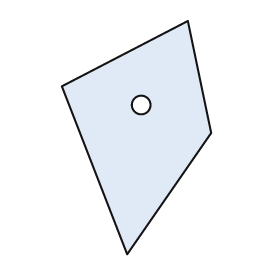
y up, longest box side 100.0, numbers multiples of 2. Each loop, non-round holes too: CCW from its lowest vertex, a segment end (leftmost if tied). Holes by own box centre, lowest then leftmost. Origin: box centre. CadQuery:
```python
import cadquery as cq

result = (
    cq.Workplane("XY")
    .moveTo(-4.0, -50.0)
    .lineTo(32.0, 2.0)
    .lineTo(22.0, 50.0)
    .lineTo(-32.0, 22.0)
    .close()
    .moveTo(2.0, 14.0)
    .circle(4.0)
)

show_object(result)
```